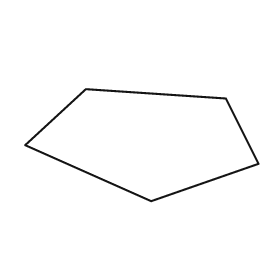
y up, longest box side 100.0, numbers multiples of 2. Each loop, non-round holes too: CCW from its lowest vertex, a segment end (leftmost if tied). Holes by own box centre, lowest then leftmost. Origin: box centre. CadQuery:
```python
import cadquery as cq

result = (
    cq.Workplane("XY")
    .moveTo(4.0, -24.0)
    .lineTo(50.0, -8.0)
    .lineTo(36.0, 20.0)
    .lineTo(-24.0, 24.0)
    .lineTo(-50.0, 0.0)
    .close()
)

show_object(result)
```